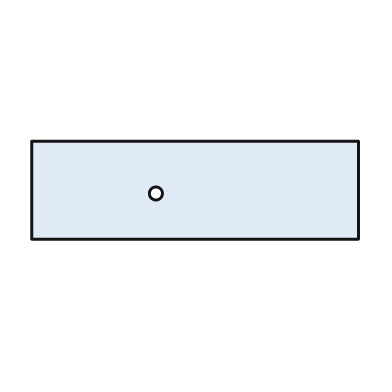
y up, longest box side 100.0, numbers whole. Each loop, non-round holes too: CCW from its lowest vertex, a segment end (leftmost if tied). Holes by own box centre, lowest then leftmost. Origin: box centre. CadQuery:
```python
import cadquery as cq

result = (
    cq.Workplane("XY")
    .moveTo(-50.0, -15.0)
    .lineTo(50.0, -15.0)
    .lineTo(50.0, 15.0)
    .lineTo(-50.0, 15.0)
    .close()
    .moveTo(-12.0, -1.0)
    .circle(2.0)
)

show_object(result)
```